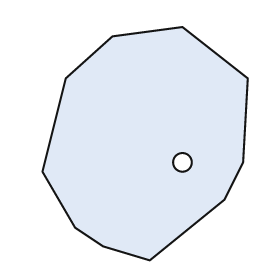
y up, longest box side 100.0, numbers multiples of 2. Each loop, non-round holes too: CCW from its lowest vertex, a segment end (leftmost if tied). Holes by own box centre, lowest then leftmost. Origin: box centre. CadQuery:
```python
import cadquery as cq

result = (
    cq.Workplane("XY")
    .moveTo(2.0, -50.0)
    .lineTo(34.0, -24.0)
    .lineTo(42.0, -8.0)
    .lineTo(44.0, 28.0)
    .lineTo(16.0, 50.0)
    .lineTo(-14.0, 46.0)
    .lineTo(-34.0, 28.0)
    .lineTo(-44.0, -12.0)
    .lineTo(-30.0, -36.0)
    .lineTo(-18.0, -44.0)
    .close()
    .moveTo(16.0, -8.0)
    .circle(4.0)
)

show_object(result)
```